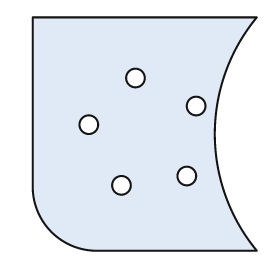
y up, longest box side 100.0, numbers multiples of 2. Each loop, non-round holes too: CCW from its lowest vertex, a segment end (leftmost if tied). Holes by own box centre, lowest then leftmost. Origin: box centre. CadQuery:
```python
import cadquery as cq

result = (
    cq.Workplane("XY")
    .moveTo(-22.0, -50.0)
    .lineTo(48.0, -50.0)
    .threePointArc((30.0, 0.0), (48.0, 50.0))
    .lineTo(-48.0, 50.0)
    .lineTo(-48.0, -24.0)
    .threePointArc((-40.0, -42.0), (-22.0, -50.0))
    .close()
    .moveTo(-10.0, -22.0)
    .circle(4.0)
    .moveTo(18.0, -18.0)
    .circle(4.0)
    .moveTo(-24.0, 4.0)
    .circle(4.0)
    .moveTo(22.0, 12.0)
    .circle(4.0)
    .moveTo(-4.0, 24.0)
    .circle(4.0)
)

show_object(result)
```